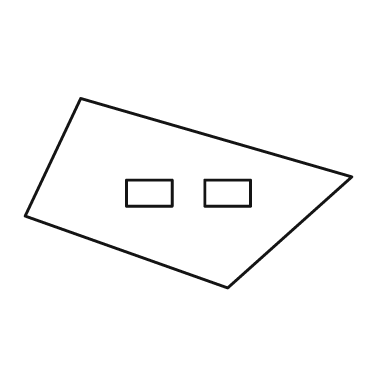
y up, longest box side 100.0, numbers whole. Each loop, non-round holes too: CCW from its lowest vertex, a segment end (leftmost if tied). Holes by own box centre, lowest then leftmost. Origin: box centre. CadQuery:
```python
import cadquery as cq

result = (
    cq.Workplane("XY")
    .moveTo(12.0, -29.0)
    .lineTo(50.0, 5.0)
    .lineTo(-33.0, 29.0)
    .lineTo(-50.0, -7.0)
    .close()
    .moveTo(-19.0, -4.0)
    .lineTo(-5.0, -4.0)
    .lineTo(-5.0, 4.0)
    .lineTo(-19.0, 4.0)
    .close()
    .moveTo(5.0, -4.0)
    .lineTo(19.0, -4.0)
    .lineTo(19.0, 4.0)
    .lineTo(5.0, 4.0)
    .close()
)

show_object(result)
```